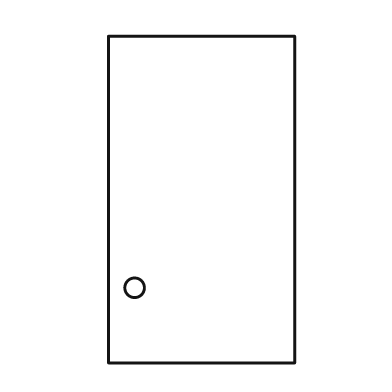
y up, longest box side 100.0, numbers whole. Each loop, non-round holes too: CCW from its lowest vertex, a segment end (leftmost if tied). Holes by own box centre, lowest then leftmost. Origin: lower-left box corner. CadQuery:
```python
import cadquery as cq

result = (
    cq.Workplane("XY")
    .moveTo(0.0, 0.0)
    .lineTo(57.0, 0.0)
    .lineTo(57.0, 100.0)
    .lineTo(0.0, 100.0)
    .close()
    .moveTo(8.0, 23.0)
    .circle(3.0)
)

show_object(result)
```